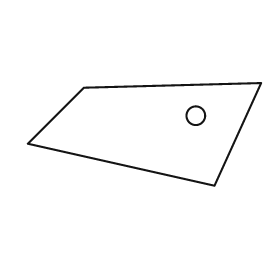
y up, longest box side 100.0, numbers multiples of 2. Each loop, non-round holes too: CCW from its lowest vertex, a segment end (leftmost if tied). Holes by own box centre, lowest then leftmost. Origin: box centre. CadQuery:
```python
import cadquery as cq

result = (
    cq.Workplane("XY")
    .moveTo(30.0, -22.0)
    .lineTo(50.0, 22.0)
    .lineTo(-26.0, 20.0)
    .lineTo(-50.0, -4.0)
    .close()
    .moveTo(22.0, 8.0)
    .circle(4.0)
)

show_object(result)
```